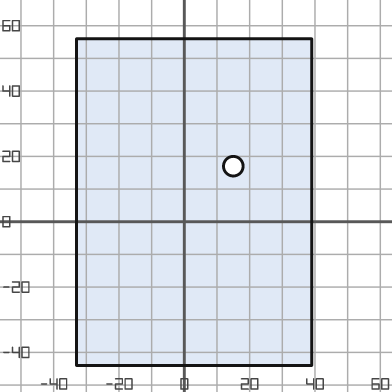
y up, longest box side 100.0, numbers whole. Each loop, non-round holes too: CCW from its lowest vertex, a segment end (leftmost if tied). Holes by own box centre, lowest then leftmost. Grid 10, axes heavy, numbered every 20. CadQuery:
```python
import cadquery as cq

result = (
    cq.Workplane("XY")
    .moveTo(-33.0, -44.0)
    .lineTo(39.0, -44.0)
    .lineTo(39.0, 56.0)
    .lineTo(-33.0, 56.0)
    .close()
    .moveTo(15.0, 17.0)
    .circle(3.0)
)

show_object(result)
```